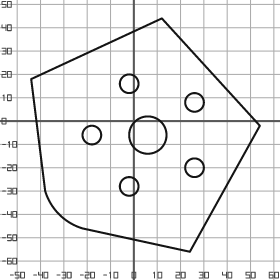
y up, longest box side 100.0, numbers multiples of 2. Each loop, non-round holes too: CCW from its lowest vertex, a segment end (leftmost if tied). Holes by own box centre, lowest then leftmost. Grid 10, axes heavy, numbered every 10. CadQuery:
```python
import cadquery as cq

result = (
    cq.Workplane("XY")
    .moveTo(24.0, -56.0)
    .lineTo(54.0, -2.0)
    .lineTo(12.0, 44.0)
    .lineTo(-44.0, 18.0)
    .lineTo(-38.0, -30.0)
    .threePointArc((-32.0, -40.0), (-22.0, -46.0))
    .close()
    .moveTo(-2.0, -28.0)
    .circle(4.0)
    .moveTo(26.0, -20.0)
    .circle(4.0)
    .moveTo(-18.0, -6.0)
    .circle(4.0)
    .moveTo(6.0, -6.0)
    .circle(8.0)
    .moveTo(26.0, 8.0)
    .circle(4.0)
    .moveTo(-2.0, 16.0)
    .circle(4.0)
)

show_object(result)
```